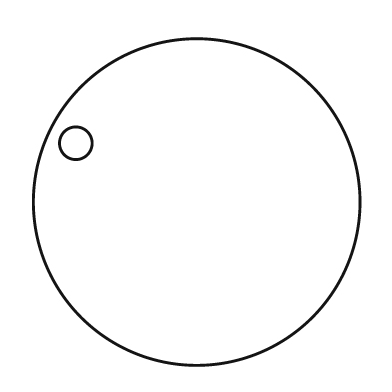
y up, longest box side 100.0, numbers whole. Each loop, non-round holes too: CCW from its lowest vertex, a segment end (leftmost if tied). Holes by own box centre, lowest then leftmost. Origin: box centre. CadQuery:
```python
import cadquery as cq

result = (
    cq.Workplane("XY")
    .moveTo(0.0, 0.0)
    .circle(50.0)
    .moveTo(-37.0, 18.0)
    .circle(5.0)
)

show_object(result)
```